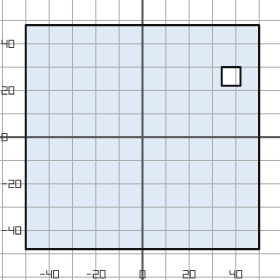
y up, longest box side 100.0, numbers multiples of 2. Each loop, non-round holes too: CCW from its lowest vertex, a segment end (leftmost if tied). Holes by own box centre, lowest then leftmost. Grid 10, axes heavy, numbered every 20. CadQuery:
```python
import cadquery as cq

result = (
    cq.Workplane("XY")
    .moveTo(-50.0, -48.0)
    .lineTo(50.0, -48.0)
    .lineTo(50.0, 48.0)
    .lineTo(-50.0, 48.0)
    .close()
    .moveTo(34.0, 22.0)
    .lineTo(42.0, 22.0)
    .lineTo(42.0, 30.0)
    .lineTo(34.0, 30.0)
    .close()
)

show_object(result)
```